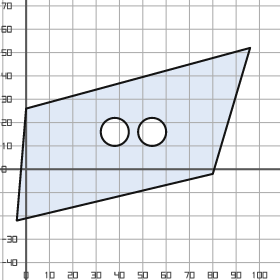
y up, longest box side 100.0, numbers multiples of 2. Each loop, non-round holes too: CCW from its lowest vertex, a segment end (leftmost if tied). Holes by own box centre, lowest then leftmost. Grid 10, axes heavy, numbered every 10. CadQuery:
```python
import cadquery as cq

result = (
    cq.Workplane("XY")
    .moveTo(-4.0, -22.0)
    .lineTo(80.0, -2.0)
    .lineTo(96.0, 52.0)
    .lineTo(0.0, 26.0)
    .close()
    .moveTo(38.0, 16.0)
    .circle(6.0)
    .moveTo(54.0, 16.0)
    .circle(6.0)
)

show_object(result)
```